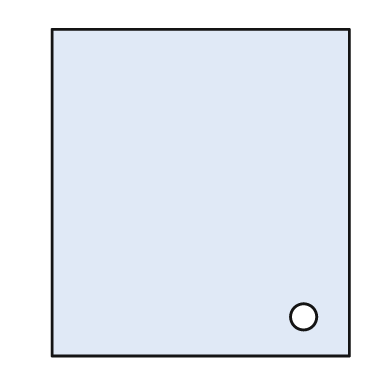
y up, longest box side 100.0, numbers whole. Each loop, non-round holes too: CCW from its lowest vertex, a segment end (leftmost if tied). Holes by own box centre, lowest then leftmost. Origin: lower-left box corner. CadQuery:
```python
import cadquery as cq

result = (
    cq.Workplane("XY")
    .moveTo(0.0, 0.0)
    .lineTo(91.0, 0.0)
    .lineTo(91.0, 100.0)
    .lineTo(0.0, 100.0)
    .close()
    .moveTo(77.0, 12.0)
    .circle(4.0)
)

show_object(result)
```